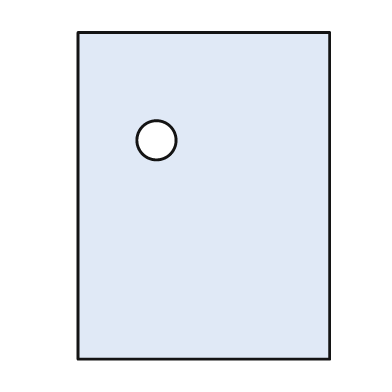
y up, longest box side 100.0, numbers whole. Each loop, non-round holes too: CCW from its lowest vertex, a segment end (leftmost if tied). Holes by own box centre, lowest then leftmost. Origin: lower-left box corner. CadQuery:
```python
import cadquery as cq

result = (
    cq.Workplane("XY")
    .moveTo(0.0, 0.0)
    .lineTo(77.0, 0.0)
    .lineTo(77.0, 100.0)
    .lineTo(0.0, 100.0)
    .close()
    .moveTo(24.0, 67.0)
    .circle(6.0)
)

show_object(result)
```